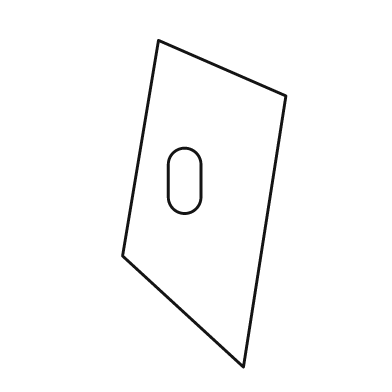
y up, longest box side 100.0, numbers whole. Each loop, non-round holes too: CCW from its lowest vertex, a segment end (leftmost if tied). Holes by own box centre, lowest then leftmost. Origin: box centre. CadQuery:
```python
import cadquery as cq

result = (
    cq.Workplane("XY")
    .moveTo(12.0, -50.0)
    .lineTo(25.0, 33.0)
    .lineTo(-14.0, 50.0)
    .lineTo(-25.0, -16.0)
    .close()
    .moveTo(-11.0, 2.0)
    .threePointArc((-6.0, -3.0), (-1.0, 2.0))
    .lineTo(-1.0, 12.0)
    .threePointArc((-6.0, 17.0), (-11.0, 12.0))
    .close()
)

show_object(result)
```